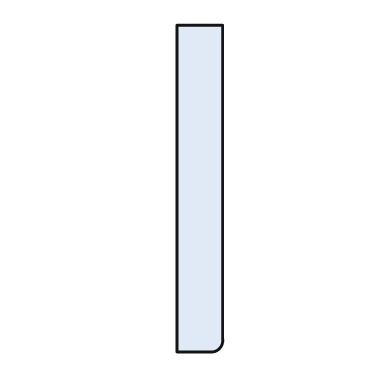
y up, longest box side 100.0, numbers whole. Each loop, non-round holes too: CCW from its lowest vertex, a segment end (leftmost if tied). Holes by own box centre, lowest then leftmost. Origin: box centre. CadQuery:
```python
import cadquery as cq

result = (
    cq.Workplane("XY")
    .moveTo(-7.0, -50.0)
    .lineTo(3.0, -50.0)
    .threePointArc((6.0, -49.0), (7.0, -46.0))
    .lineTo(7.0, 50.0)
    .lineTo(-7.0, 50.0)
    .close()
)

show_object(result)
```